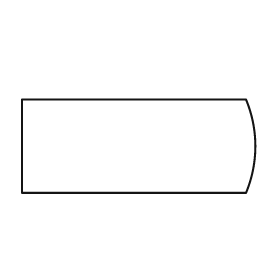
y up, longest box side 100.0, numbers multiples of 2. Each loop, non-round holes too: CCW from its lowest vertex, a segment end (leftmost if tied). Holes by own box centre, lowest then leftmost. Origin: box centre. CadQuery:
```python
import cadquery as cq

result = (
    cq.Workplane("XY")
    .moveTo(-50.0, -20.0)
    .lineTo(46.0, -20.0)
    .threePointArc((50.0, 0.0), (46.0, 20.0))
    .lineTo(-50.0, 20.0)
    .close()
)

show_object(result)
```